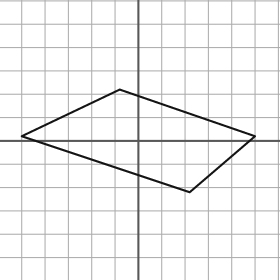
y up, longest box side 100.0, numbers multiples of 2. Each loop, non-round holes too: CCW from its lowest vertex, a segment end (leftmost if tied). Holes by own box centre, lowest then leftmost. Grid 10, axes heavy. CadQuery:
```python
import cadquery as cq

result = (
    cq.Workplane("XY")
    .moveTo(22.0, -22.0)
    .lineTo(50.0, 2.0)
    .lineTo(-8.0, 22.0)
    .lineTo(-50.0, 2.0)
    .close()
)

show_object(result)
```